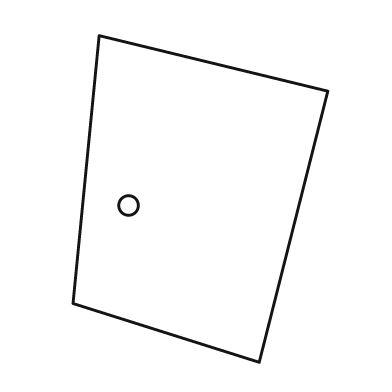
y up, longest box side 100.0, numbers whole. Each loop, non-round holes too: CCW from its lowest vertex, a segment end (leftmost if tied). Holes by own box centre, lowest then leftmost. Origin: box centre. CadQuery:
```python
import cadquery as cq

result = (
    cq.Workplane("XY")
    .moveTo(18.0, -50.0)
    .lineTo(39.0, 33.0)
    .lineTo(-31.0, 50.0)
    .lineTo(-39.0, -32.0)
    .close()
    .moveTo(-22.0, -2.0)
    .circle(3.0)
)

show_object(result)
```